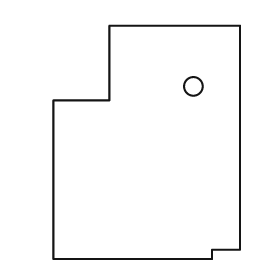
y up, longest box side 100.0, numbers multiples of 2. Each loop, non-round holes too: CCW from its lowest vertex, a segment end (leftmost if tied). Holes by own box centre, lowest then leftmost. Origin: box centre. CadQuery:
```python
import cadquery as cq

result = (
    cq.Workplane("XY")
    .moveTo(-40.0, -50.0)
    .lineTo(28.0, -50.0)
    .lineTo(28.0, -46.0)
    .lineTo(40.0, -46.0)
    .lineTo(40.0, 50.0)
    .lineTo(-16.0, 50.0)
    .lineTo(-16.0, 18.0)
    .lineTo(-40.0, 18.0)
    .close()
    .moveTo(20.0, 24.0)
    .circle(4.0)
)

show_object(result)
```